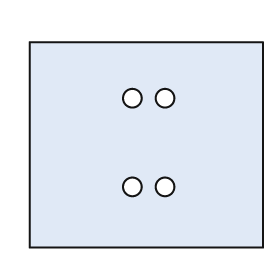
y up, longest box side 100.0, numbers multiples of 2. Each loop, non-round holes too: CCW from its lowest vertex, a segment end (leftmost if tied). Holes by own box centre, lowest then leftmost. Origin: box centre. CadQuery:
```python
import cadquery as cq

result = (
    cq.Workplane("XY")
    .moveTo(-50.0, -44.0)
    .lineTo(50.0, -44.0)
    .lineTo(50.0, 44.0)
    .lineTo(-50.0, 44.0)
    .close()
    .moveTo(-6.0, -18.0)
    .circle(4.0)
    .moveTo(8.0, -18.0)
    .circle(4.0)
    .moveTo(-6.0, 20.0)
    .circle(4.0)
    .moveTo(8.0, 20.0)
    .circle(4.0)
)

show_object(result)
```